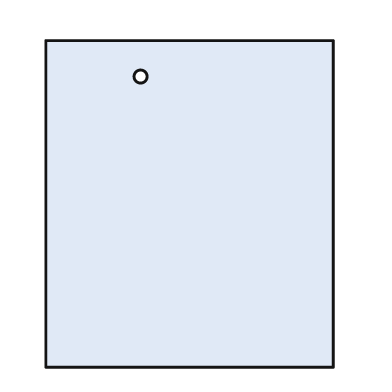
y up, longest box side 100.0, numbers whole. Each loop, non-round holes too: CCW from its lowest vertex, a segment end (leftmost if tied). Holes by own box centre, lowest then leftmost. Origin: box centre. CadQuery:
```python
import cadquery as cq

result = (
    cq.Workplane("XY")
    .moveTo(-44.0, -50.0)
    .lineTo(44.0, -50.0)
    .lineTo(44.0, 50.0)
    .lineTo(-44.0, 50.0)
    .close()
    .moveTo(-15.0, 39.0)
    .circle(2.0)
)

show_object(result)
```